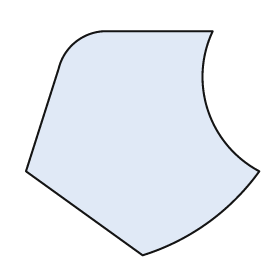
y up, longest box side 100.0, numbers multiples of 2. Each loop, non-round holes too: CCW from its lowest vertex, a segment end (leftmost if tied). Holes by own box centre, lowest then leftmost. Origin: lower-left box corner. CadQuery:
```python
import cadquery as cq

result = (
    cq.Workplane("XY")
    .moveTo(50.0, 0.0)
    .threePointArc((78.0, 14.0), (100.0, 36.0))
    .threePointArc((78.0, 62.0), (80.0, 96.0))
    .lineTo(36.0, 96.0)
    .threePointArc((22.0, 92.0), (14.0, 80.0))
    .lineTo(0.0, 36.0)
    .close()
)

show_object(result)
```